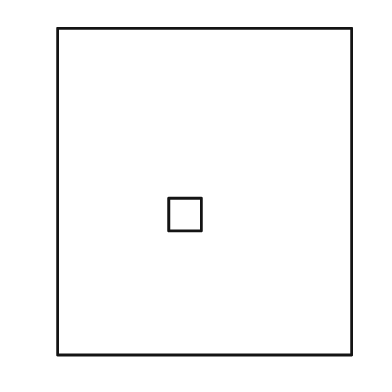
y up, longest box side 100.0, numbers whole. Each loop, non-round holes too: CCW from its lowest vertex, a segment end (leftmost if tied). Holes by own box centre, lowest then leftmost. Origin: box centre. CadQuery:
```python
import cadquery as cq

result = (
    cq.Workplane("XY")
    .moveTo(-45.0, -50.0)
    .lineTo(45.0, -50.0)
    .lineTo(45.0, 50.0)
    .lineTo(-45.0, 50.0)
    .close()
    .moveTo(-11.0, -12.0)
    .lineTo(-1.0, -12.0)
    .lineTo(-1.0, -2.0)
    .lineTo(-11.0, -2.0)
    .close()
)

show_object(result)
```